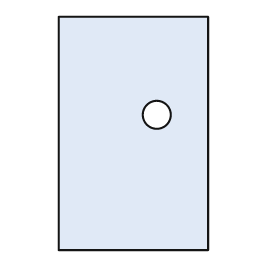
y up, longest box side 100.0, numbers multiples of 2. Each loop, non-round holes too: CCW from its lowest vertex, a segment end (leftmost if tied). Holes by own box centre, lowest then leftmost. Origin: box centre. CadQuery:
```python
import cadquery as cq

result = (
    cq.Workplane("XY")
    .moveTo(-32.0, -50.0)
    .lineTo(32.0, -50.0)
    .lineTo(32.0, 50.0)
    .lineTo(-32.0, 50.0)
    .close()
    .moveTo(10.0, 8.0)
    .circle(6.0)
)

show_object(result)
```